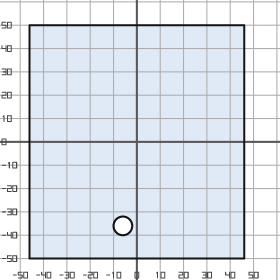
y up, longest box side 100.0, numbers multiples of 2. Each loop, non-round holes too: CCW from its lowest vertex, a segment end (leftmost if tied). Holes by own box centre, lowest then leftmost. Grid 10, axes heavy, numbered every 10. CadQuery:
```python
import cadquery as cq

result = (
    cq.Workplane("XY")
    .moveTo(-46.0, -50.0)
    .lineTo(46.0, -50.0)
    .lineTo(46.0, 50.0)
    .lineTo(-46.0, 50.0)
    .close()
    .moveTo(-6.0, -36.0)
    .circle(4.0)
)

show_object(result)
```